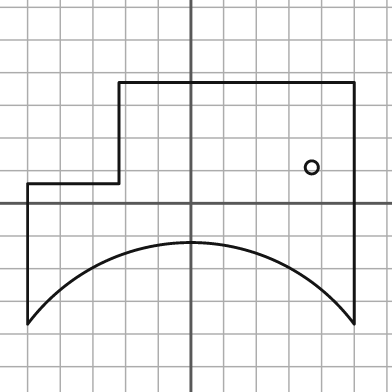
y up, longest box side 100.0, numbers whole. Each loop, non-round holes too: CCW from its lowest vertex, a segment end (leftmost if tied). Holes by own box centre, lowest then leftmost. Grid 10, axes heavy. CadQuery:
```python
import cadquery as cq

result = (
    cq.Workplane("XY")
    .moveTo(-50.0, -37.0)
    .threePointArc((0.0, -12.0), (50.0, -37.0))
    .lineTo(50.0, 37.0)
    .lineTo(-22.0, 37.0)
    .lineTo(-22.0, 6.0)
    .lineTo(-50.0, 6.0)
    .close()
    .moveTo(37.0, 11.0)
    .circle(2.0)
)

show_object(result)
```